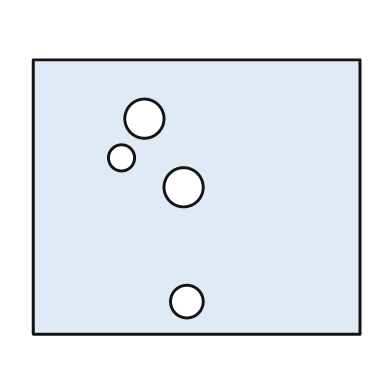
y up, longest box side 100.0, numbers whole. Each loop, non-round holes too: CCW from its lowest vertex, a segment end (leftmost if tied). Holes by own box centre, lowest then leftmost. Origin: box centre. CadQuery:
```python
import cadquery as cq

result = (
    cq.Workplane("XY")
    .moveTo(-50.0, -42.0)
    .lineTo(50.0, -42.0)
    .lineTo(50.0, 42.0)
    .lineTo(-50.0, 42.0)
    .close()
    .moveTo(-3.0, -32.0)
    .circle(5.0)
    .moveTo(-4.0, 3.0)
    .circle(6.0)
    .moveTo(-23.0, 12.0)
    .circle(4.0)
    .moveTo(-16.0, 24.0)
    .circle(6.0)
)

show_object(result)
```